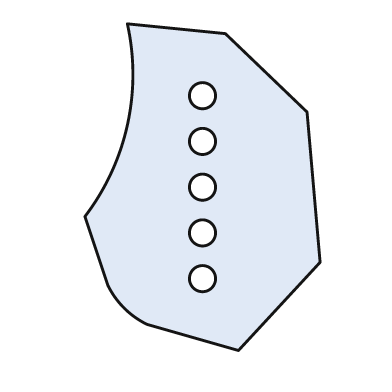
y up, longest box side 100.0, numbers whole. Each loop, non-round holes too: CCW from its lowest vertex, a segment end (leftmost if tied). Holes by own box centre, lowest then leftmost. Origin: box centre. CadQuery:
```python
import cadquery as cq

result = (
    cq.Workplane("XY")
    .moveTo(11.0, -50.0)
    .lineTo(36.0, -23.0)
    .lineTo(32.0, 23.0)
    .lineTo(7.0, 47.0)
    .lineTo(-23.0, 50.0)
    .threePointArc((-23.0, 19.0), (-36.0, -9.0))
    .lineTo(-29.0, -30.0)
    .threePointArc((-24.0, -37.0), (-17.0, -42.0))
    .close()
    .moveTo(0.0, -28.0)
    .circle(4.0)
    .moveTo(0.0, -14.0)
    .circle(4.0)
    .moveTo(0.0, 0.0)
    .circle(4.0)
    .moveTo(0.0, 14.0)
    .circle(4.0)
    .moveTo(0.0, 28.0)
    .circle(4.0)
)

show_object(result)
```